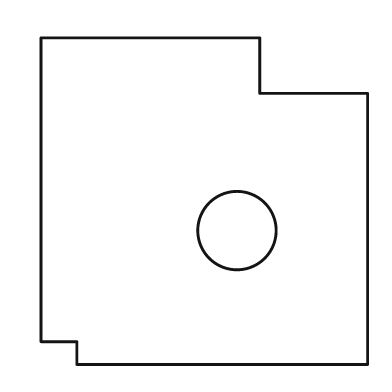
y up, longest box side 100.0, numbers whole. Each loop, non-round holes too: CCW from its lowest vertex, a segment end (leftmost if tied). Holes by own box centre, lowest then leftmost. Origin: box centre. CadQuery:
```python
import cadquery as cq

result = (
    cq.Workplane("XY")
    .moveTo(-39.0, -50.0)
    .lineTo(50.0, -50.0)
    .lineTo(50.0, 33.0)
    .lineTo(17.0, 33.0)
    .lineTo(17.0, 50.0)
    .lineTo(-50.0, 50.0)
    .lineTo(-50.0, -43.0)
    .lineTo(-39.0, -43.0)
    .close()
    .moveTo(10.0, -9.0)
    .circle(12.0)
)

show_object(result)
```